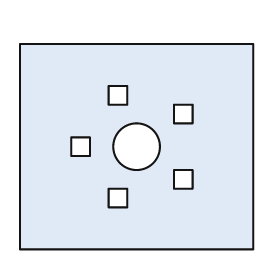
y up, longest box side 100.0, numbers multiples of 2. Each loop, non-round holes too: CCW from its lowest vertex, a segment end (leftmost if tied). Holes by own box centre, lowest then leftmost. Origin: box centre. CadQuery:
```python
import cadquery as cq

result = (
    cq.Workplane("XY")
    .moveTo(-50.0, -44.0)
    .lineTo(50.0, -44.0)
    .lineTo(50.0, 44.0)
    .lineTo(-50.0, 44.0)
    .close()
    .moveTo(-12.0, -26.0)
    .lineTo(-4.0, -26.0)
    .lineTo(-4.0, -18.0)
    .lineTo(-12.0, -18.0)
    .close()
    .moveTo(16.0, -18.0)
    .lineTo(24.0, -18.0)
    .lineTo(24.0, -10.0)
    .lineTo(16.0, -10.0)
    .close()
    .moveTo(-28.0, -4.0)
    .lineTo(-20.0, -4.0)
    .lineTo(-20.0, 4.0)
    .lineTo(-28.0, 4.0)
    .close()
    .moveTo(0.0, 0.0)
    .circle(10.0)
    .moveTo(16.0, 10.0)
    .lineTo(24.0, 10.0)
    .lineTo(24.0, 18.0)
    .lineTo(16.0, 18.0)
    .close()
    .moveTo(-12.0, 18.0)
    .lineTo(-4.0, 18.0)
    .lineTo(-4.0, 26.0)
    .lineTo(-12.0, 26.0)
    .close()
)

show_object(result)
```